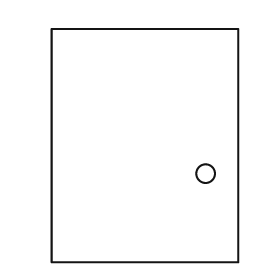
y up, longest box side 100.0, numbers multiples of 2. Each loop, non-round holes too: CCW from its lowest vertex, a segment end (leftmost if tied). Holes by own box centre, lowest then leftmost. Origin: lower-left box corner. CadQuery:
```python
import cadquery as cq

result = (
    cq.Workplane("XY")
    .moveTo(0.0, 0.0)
    .lineTo(80.0, 0.0)
    .lineTo(80.0, 100.0)
    .lineTo(0.0, 100.0)
    .close()
    .moveTo(66.0, 38.0)
    .circle(4.0)
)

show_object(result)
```